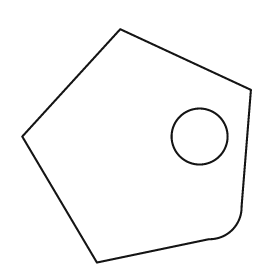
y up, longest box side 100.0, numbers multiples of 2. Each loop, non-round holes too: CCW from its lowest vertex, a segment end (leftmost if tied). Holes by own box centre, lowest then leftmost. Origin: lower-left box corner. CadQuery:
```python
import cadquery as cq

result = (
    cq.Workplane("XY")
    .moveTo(32.0, 0.0)
    .lineTo(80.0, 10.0)
    .threePointArc((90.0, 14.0), (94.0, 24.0))
    .lineTo(98.0, 74.0)
    .lineTo(42.0, 100.0)
    .lineTo(0.0, 54.0)
    .close()
    .moveTo(76.0, 54.0)
    .circle(12.0)
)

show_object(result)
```